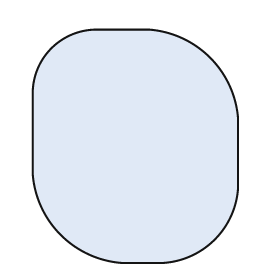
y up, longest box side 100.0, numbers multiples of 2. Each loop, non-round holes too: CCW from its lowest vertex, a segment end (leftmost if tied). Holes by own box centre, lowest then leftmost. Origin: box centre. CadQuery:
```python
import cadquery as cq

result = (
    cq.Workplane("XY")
    .moveTo(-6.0, -50.0)
    .lineTo(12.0, -50.0)
    .threePointArc((34.0, -40.0), (44.0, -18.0))
    .lineTo(44.0, 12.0)
    .threePointArc((32.0, 38.0), (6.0, 50.0))
    .lineTo(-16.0, 50.0)
    .threePointArc((-36.0, 42.0), (-44.0, 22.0))
    .lineTo(-44.0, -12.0)
    .threePointArc((-32.0, -38.0), (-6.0, -50.0))
    .close()
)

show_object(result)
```